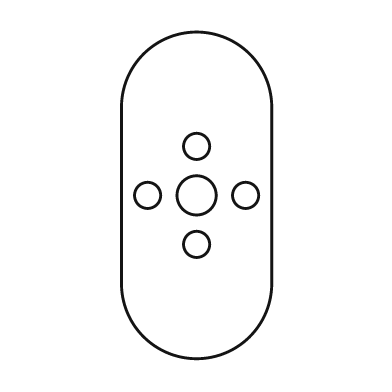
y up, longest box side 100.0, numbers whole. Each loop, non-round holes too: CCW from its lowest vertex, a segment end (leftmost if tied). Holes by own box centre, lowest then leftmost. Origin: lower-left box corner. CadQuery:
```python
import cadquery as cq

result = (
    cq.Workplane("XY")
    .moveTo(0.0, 23.0)
    .threePointArc((23.0, 0.0), (46.0, 23.0))
    .lineTo(46.0, 77.0)
    .threePointArc((23.0, 100.0), (0.0, 77.0))
    .close()
    .moveTo(23.0, 35.0)
    .circle(4.0)
    .moveTo(8.0, 50.0)
    .circle(4.0)
    .moveTo(23.0, 50.0)
    .circle(6.0)
    .moveTo(38.0, 50.0)
    .circle(4.0)
    .moveTo(23.0, 65.0)
    .circle(4.0)
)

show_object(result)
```